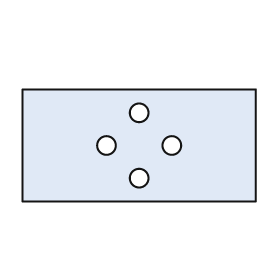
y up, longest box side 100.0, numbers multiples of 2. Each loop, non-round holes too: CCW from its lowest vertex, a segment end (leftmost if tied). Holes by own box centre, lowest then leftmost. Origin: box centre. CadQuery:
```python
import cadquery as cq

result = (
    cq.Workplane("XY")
    .moveTo(-50.0, -24.0)
    .lineTo(50.0, -24.0)
    .lineTo(50.0, 24.0)
    .lineTo(-50.0, 24.0)
    .close()
    .moveTo(0.0, -14.0)
    .circle(4.0)
    .moveTo(-14.0, 0.0)
    .circle(4.0)
    .moveTo(14.0, 0.0)
    .circle(4.0)
    .moveTo(0.0, 14.0)
    .circle(4.0)
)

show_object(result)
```